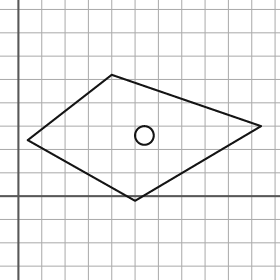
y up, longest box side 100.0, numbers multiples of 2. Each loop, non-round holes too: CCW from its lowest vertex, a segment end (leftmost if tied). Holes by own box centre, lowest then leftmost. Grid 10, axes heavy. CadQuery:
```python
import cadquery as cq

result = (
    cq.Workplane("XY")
    .moveTo(50.0, -2.0)
    .lineTo(104.0, 30.0)
    .lineTo(40.0, 52.0)
    .lineTo(4.0, 24.0)
    .close()
    .moveTo(54.0, 26.0)
    .circle(4.0)
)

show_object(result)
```